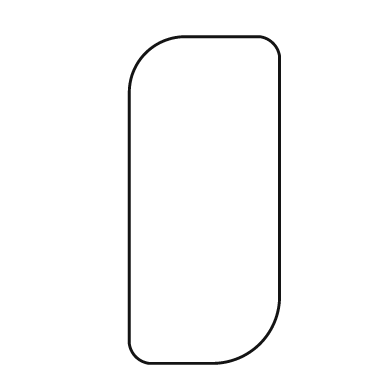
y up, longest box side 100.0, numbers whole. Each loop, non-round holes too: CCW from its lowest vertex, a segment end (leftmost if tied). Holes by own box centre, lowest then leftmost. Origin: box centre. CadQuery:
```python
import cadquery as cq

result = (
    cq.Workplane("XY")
    .moveTo(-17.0, -50.0)
    .lineTo(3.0, -50.0)
    .threePointArc((17.0, -44.0), (23.0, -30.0))
    .lineTo(23.0, 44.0)
    .threePointArc((21.0, 48.0), (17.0, 50.0))
    .lineTo(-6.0, 50.0)
    .threePointArc((-18.0, 45.0), (-23.0, 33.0))
    .lineTo(-23.0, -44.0)
    .threePointArc((-21.0, -48.0), (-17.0, -50.0))
    .close()
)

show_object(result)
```